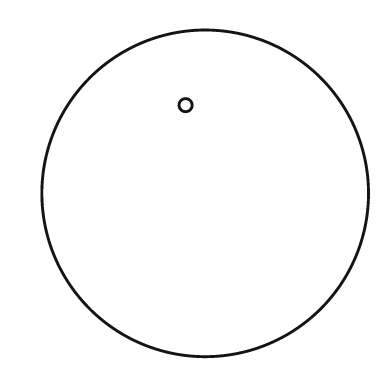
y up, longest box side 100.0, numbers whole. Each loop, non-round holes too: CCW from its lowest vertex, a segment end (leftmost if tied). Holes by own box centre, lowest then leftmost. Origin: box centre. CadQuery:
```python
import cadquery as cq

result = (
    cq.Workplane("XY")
    .moveTo(0.0, 0.0)
    .circle(50.0)
    .moveTo(-6.0, 27.0)
    .circle(2.0)
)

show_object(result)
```